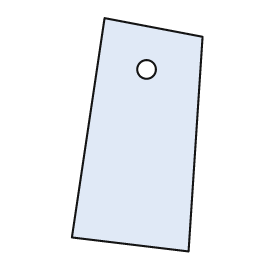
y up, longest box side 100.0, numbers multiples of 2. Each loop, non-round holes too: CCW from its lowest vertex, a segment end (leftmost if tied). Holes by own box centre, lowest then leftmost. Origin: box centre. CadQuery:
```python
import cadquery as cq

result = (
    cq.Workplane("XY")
    .moveTo(22.0, -50.0)
    .lineTo(28.0, 42.0)
    .lineTo(-14.0, 50.0)
    .lineTo(-28.0, -44.0)
    .close()
    .moveTo(4.0, 28.0)
    .circle(4.0)
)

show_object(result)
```